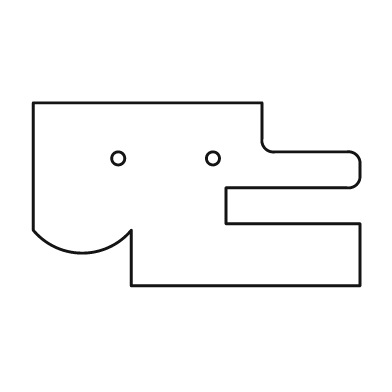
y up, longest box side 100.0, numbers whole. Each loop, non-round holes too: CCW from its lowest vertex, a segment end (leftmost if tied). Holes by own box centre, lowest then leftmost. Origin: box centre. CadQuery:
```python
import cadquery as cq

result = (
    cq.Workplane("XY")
    .moveTo(-20.0, -28.0)
    .lineTo(50.0, -28.0)
    .lineTo(50.0, -9.0)
    .lineTo(9.0, -9.0)
    .lineTo(9.0, 2.0)
    .lineTo(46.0, 2.0)
    .threePointArc((49.0, 3.0), (50.0, 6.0))
    .lineTo(50.0, 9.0)
    .threePointArc((49.0, 12.0), (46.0, 13.0))
    .lineTo(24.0, 13.0)
    .threePointArc((21.0, 14.0), (20.0, 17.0))
    .lineTo(20.0, 28.0)
    .lineTo(-50.0, 28.0)
    .lineTo(-50.0, -11.0)
    .threePointArc((-35.0, -18.0), (-20.0, -11.0))
    .close()
    .moveTo(-24.0, 11.0)
    .circle(2.0)
    .moveTo(5.0, 11.0)
    .circle(2.0)
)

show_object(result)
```